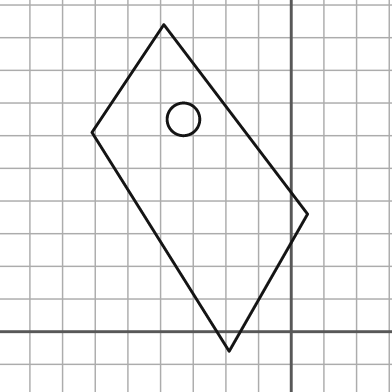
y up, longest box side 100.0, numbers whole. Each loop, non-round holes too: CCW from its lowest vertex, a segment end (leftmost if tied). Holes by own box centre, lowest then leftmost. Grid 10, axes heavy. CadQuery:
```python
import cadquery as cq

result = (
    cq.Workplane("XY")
    .moveTo(-19.0, -6.0)
    .lineTo(5.0, 36.0)
    .lineTo(-39.0, 94.0)
    .lineTo(-61.0, 61.0)
    .close()
    .moveTo(-33.0, 65.0)
    .circle(5.0)
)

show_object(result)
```